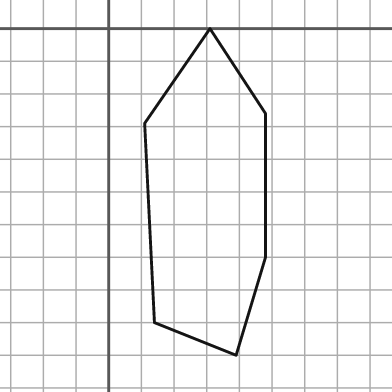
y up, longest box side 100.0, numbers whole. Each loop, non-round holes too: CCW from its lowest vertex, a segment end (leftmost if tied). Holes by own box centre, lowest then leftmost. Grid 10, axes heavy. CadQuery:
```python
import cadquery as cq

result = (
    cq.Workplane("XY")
    .moveTo(39.0, -100.0)
    .lineTo(48.0, -70.0)
    .lineTo(48.0, -26.0)
    .lineTo(31.0, 0.0)
    .lineTo(11.0, -29.0)
    .lineTo(14.0, -90.0)
    .close()
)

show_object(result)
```